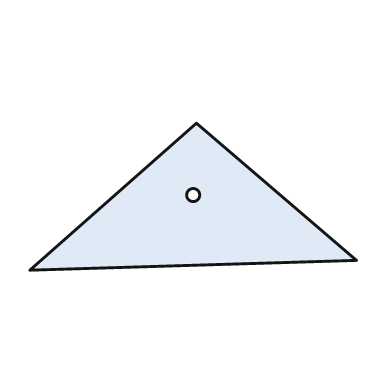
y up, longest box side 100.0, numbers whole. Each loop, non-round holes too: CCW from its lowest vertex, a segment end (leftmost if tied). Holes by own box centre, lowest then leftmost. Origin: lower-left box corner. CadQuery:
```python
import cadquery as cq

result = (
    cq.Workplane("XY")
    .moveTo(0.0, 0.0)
    .lineTo(100.0, 3.0)
    .lineTo(51.0, 45.0)
    .close()
    .moveTo(50.0, 23.0)
    .circle(2.0)
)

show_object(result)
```